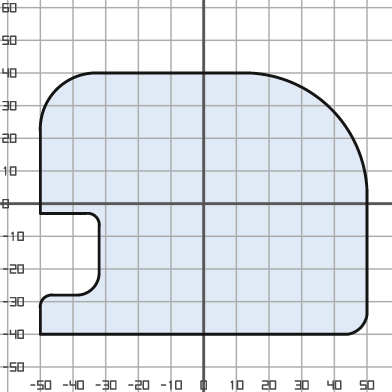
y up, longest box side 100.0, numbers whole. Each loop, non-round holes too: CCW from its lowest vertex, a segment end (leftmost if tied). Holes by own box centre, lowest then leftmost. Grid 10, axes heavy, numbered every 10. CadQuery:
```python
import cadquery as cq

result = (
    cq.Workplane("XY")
    .moveTo(-50.0, -40.0)
    .lineTo(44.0, -40.0)
    .threePointArc((48.0, -38.0), (50.0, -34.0))
    .lineTo(50.0, 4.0)
    .threePointArc((39.0, 29.0), (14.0, 40.0))
    .lineTo(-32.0, 40.0)
    .threePointArc((-45.0, 35.0), (-50.0, 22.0))
    .lineTo(-50.0, -3.0)
    .lineTo(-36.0, -3.0)
    .threePointArc((-33.0, -4.0), (-32.0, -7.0))
    .lineTo(-32.0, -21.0)
    .threePointArc((-34.0, -26.0), (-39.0, -28.0))
    .lineTo(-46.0, -28.0)
    .threePointArc((-49.0, -29.0), (-50.0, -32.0))
    .close()
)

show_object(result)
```